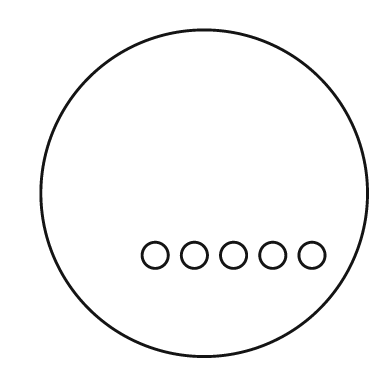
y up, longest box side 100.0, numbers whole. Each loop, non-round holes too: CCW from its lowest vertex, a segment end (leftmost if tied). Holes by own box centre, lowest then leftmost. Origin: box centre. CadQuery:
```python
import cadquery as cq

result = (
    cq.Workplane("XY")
    .moveTo(0.0, 0.0)
    .circle(50.0)
    .moveTo(-15.0, -19.0)
    .circle(4.0)
    .moveTo(-3.0, -19.0)
    .circle(4.0)
    .moveTo(9.0, -19.0)
    .circle(4.0)
    .moveTo(21.0, -19.0)
    .circle(4.0)
    .moveTo(33.0, -19.0)
    .circle(4.0)
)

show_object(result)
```